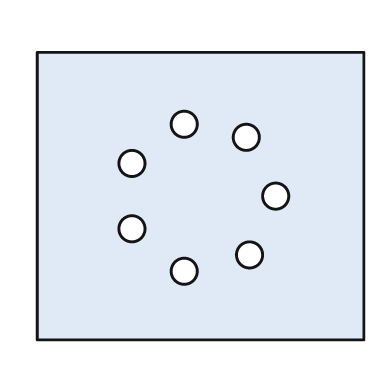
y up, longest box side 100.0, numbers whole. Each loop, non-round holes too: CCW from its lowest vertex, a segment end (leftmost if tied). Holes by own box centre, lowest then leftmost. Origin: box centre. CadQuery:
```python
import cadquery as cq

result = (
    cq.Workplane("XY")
    .moveTo(-50.0, -44.0)
    .lineTo(50.0, -44.0)
    .lineTo(50.0, 44.0)
    .lineTo(-50.0, 44.0)
    .close()
    .moveTo(-5.0, -23.0)
    .circle(4.0)
    .moveTo(15.0, -18.0)
    .circle(4.0)
    .moveTo(-21.0, -10.0)
    .circle(4.0)
    .moveTo(23.0, 0.0)
    .circle(4.0)
    .moveTo(-21.0, 10.0)
    .circle(4.0)
    .moveTo(14.0, 18.0)
    .circle(4.0)
    .moveTo(-5.0, 22.0)
    .circle(4.0)
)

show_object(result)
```